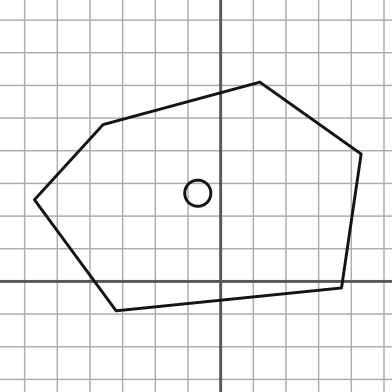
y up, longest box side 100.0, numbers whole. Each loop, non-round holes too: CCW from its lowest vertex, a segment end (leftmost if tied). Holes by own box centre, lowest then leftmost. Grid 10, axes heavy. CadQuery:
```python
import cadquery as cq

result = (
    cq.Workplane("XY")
    .moveTo(-32.0, -9.0)
    .lineTo(37.0, -2.0)
    .lineTo(43.0, 39.0)
    .lineTo(12.0, 61.0)
    .lineTo(-36.0, 48.0)
    .lineTo(-57.0, 25.0)
    .close()
    .moveTo(-7.0, 27.0)
    .circle(4.0)
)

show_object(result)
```